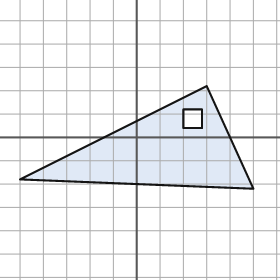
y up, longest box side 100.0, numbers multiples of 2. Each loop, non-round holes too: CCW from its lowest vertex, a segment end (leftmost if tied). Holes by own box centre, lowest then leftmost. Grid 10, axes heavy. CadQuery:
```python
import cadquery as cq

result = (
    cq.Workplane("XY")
    .moveTo(50.0, -22.0)
    .lineTo(30.0, 22.0)
    .lineTo(-50.0, -18.0)
    .close()
    .moveTo(20.0, 4.0)
    .lineTo(28.0, 4.0)
    .lineTo(28.0, 12.0)
    .lineTo(20.0, 12.0)
    .close()
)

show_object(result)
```